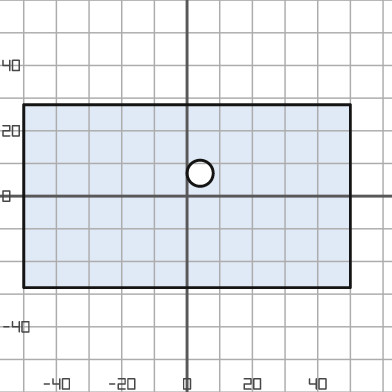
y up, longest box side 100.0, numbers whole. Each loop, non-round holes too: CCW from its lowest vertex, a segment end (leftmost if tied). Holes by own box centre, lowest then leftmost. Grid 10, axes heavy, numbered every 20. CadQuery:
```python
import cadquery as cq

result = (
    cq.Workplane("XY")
    .moveTo(-50.0, -28.0)
    .lineTo(50.0, -28.0)
    .lineTo(50.0, 28.0)
    .lineTo(-50.0, 28.0)
    .close()
    .moveTo(4.0, 7.0)
    .circle(4.0)
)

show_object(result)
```